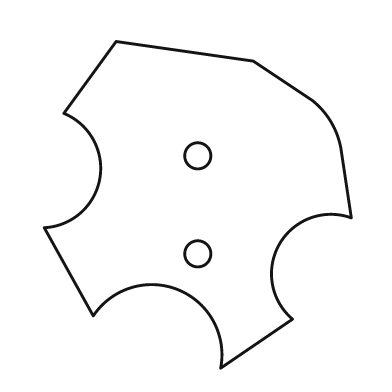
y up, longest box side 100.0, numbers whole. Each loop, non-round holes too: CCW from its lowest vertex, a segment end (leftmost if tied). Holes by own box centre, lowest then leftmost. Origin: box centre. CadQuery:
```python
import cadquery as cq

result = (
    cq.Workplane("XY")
    .moveTo(7.0, -50.0)
    .lineTo(29.0, -35.0)
    .threePointArc((25.0, -12.0), (47.0, -4.0))
    .lineTo(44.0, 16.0)
    .threePointArc((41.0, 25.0), (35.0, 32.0))
    .lineTo(17.0, 44.0)
    .lineTo(-25.0, 50.0)
    .lineTo(-41.0, 28.0)
    .threePointArc((-30.0, 8.0), (-47.0, -7.0))
    .lineTo(-32.0, -34.0)
    .threePointArc((-6.0, -26.0), (7.0, -50.0))
    .close()
    .moveTo(0.0, -15.0)
    .circle(4.0)
    .moveTo(0.0, 15.0)
    .circle(4.0)
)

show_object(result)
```